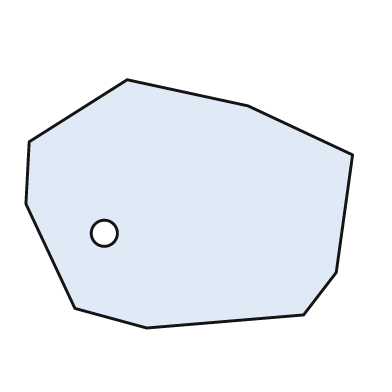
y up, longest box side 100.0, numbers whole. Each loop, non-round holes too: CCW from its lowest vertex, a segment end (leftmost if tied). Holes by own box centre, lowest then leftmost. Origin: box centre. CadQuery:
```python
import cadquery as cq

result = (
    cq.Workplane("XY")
    .moveTo(-13.0, -38.0)
    .lineTo(35.0, -34.0)
    .lineTo(45.0, -21.0)
    .lineTo(50.0, 15.0)
    .lineTo(18.0, 30.0)
    .lineTo(-19.0, 38.0)
    .lineTo(-49.0, 19.0)
    .lineTo(-50.0, 0.0)
    .lineTo(-35.0, -32.0)
    .close()
    .moveTo(-26.0, -9.0)
    .circle(4.0)
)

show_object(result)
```